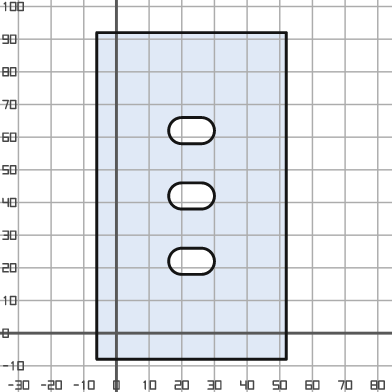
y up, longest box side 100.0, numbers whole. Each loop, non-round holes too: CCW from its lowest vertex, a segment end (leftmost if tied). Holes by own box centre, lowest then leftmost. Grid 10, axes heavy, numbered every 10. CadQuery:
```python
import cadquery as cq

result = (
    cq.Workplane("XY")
    .moveTo(-6.0, -8.0)
    .lineTo(52.0, -8.0)
    .lineTo(52.0, 92.0)
    .lineTo(-6.0, 92.0)
    .close()
    .moveTo(20.0, 18.0)
    .lineTo(26.0, 18.0)
    .threePointArc((30.0, 22.0), (26.0, 26.0))
    .lineTo(20.0, 26.0)
    .threePointArc((16.0, 22.0), (20.0, 18.0))
    .close()
    .moveTo(20.0, 38.0)
    .lineTo(26.0, 38.0)
    .threePointArc((30.0, 42.0), (26.0, 46.0))
    .lineTo(20.0, 46.0)
    .threePointArc((16.0, 42.0), (20.0, 38.0))
    .close()
    .moveTo(20.0, 58.0)
    .lineTo(26.0, 58.0)
    .threePointArc((30.0, 62.0), (26.0, 66.0))
    .lineTo(20.0, 66.0)
    .threePointArc((16.0, 62.0), (20.0, 58.0))
    .close()
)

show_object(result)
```